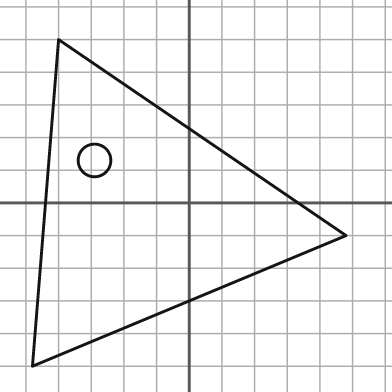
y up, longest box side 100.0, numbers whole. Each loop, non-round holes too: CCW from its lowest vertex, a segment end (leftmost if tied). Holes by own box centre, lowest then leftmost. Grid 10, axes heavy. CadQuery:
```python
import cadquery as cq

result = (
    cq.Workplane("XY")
    .moveTo(-48.0, -50.0)
    .lineTo(48.0, -10.0)
    .lineTo(-40.0, 50.0)
    .close()
    .moveTo(-29.0, 13.0)
    .circle(5.0)
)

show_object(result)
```